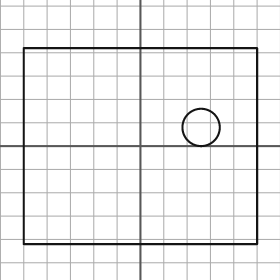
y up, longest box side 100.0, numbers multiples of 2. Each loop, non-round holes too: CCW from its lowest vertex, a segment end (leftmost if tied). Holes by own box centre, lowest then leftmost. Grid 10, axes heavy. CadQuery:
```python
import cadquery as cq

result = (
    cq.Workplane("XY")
    .moveTo(-50.0, -42.0)
    .lineTo(50.0, -42.0)
    .lineTo(50.0, 42.0)
    .lineTo(-50.0, 42.0)
    .close()
    .moveTo(26.0, 8.0)
    .circle(8.0)
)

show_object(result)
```